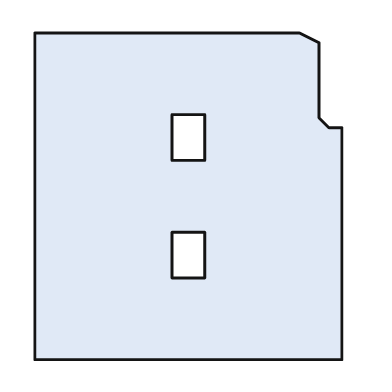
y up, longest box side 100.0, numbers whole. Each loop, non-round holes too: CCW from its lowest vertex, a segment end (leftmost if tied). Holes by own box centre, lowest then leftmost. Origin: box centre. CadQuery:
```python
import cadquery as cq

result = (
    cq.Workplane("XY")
    .moveTo(-47.0, -50.0)
    .lineTo(47.0, -50.0)
    .lineTo(47.0, 21.0)
    .lineTo(43.0, 21.0)
    .lineTo(40.0, 24.0)
    .lineTo(40.0, 47.0)
    .lineTo(34.0, 50.0)
    .lineTo(-47.0, 50.0)
    .close()
    .moveTo(-5.0, -25.0)
    .lineTo(5.0, -25.0)
    .lineTo(5.0, -11.0)
    .lineTo(-5.0, -11.0)
    .close()
    .moveTo(-5.0, 11.0)
    .lineTo(5.0, 11.0)
    .lineTo(5.0, 25.0)
    .lineTo(-5.0, 25.0)
    .close()
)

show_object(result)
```